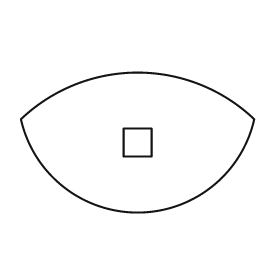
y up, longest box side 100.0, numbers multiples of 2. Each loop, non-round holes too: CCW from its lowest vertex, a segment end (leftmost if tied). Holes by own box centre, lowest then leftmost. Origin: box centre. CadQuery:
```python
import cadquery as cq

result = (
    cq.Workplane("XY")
    .moveTo(-50.0, 10.0)
    .threePointArc((0.0, -30.0), (50.0, 10.0))
    .threePointArc((0.0, 30.0), (-50.0, 10.0))
    .close()
    .moveTo(-6.0, -6.0)
    .lineTo(6.0, -6.0)
    .lineTo(6.0, 6.0)
    .lineTo(-6.0, 6.0)
    .close()
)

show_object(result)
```